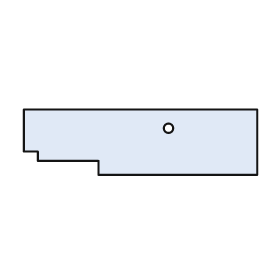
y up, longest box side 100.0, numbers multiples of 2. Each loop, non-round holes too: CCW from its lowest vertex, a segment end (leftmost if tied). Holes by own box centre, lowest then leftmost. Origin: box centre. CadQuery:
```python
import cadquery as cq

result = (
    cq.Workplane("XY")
    .moveTo(-18.0, -14.0)
    .lineTo(50.0, -14.0)
    .lineTo(50.0, 14.0)
    .lineTo(-50.0, 14.0)
    .lineTo(-50.0, -4.0)
    .lineTo(-44.0, -4.0)
    .lineTo(-44.0, -8.0)
    .lineTo(-18.0, -8.0)
    .close()
    .moveTo(12.0, 6.0)
    .circle(2.0)
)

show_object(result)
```